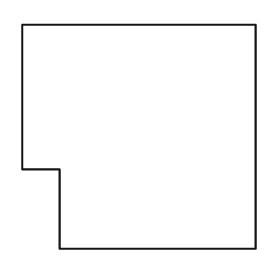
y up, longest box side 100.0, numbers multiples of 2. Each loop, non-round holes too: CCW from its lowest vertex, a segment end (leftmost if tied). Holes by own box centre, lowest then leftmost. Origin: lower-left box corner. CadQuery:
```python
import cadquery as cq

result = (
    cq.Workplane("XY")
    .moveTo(16.0, 0.0)
    .lineTo(100.0, 0.0)
    .lineTo(100.0, 96.0)
    .lineTo(0.0, 96.0)
    .lineTo(0.0, 34.0)
    .lineTo(16.0, 34.0)
    .close()
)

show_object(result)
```